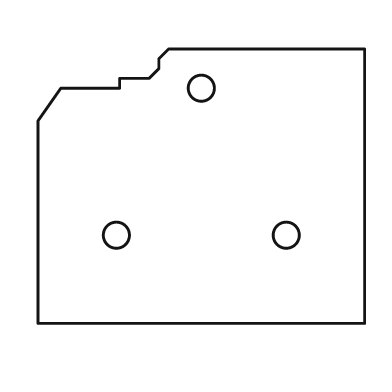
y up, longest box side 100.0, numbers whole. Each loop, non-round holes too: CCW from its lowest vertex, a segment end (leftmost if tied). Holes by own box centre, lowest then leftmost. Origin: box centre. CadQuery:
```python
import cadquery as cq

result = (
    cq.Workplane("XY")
    .moveTo(-50.0, -42.0)
    .lineTo(50.0, -42.0)
    .lineTo(50.0, 42.0)
    .lineTo(-10.0, 42.0)
    .lineTo(-13.0, 39.0)
    .lineTo(-13.0, 36.0)
    .lineTo(-16.0, 33.0)
    .lineTo(-25.0, 33.0)
    .lineTo(-25.0, 30.0)
    .lineTo(-43.0, 30.0)
    .lineTo(-50.0, 20.0)
    .close()
    .moveTo(-26.0, -15.0)
    .circle(4.0)
    .moveTo(26.0, -15.0)
    .circle(4.0)
    .moveTo(0.0, 30.0)
    .circle(4.0)
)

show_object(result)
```